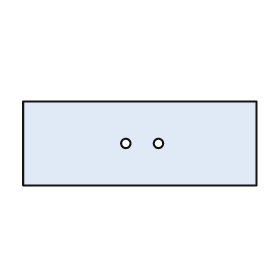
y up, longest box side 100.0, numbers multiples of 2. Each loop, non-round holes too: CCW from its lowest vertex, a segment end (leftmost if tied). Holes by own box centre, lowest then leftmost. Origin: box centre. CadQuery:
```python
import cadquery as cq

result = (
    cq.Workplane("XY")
    .moveTo(-50.0, -18.0)
    .lineTo(50.0, -18.0)
    .lineTo(50.0, 18.0)
    .lineTo(-50.0, 18.0)
    .close()
    .moveTo(-6.0, 0.0)
    .circle(2.0)
    .moveTo(8.0, 0.0)
    .circle(2.0)
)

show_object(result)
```